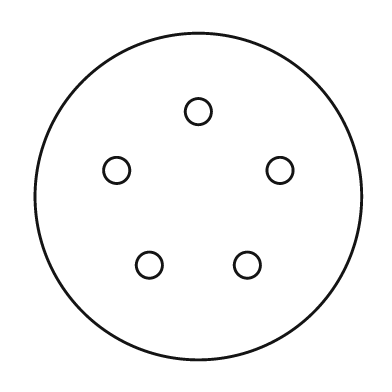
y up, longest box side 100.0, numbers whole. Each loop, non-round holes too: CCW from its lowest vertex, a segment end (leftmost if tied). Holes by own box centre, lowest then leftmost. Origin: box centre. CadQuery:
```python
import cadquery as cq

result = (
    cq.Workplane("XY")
    .moveTo(0.0, 0.0)
    .circle(50.0)
    .moveTo(-15.0, -21.0)
    .circle(4.0)
    .moveTo(15.0, -21.0)
    .circle(4.0)
    .moveTo(-25.0, 8.0)
    .circle(4.0)
    .moveTo(25.0, 8.0)
    .circle(4.0)
    .moveTo(0.0, 26.0)
    .circle(4.0)
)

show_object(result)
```